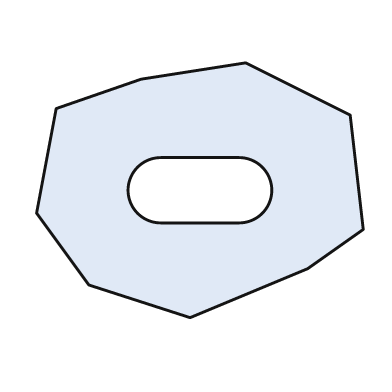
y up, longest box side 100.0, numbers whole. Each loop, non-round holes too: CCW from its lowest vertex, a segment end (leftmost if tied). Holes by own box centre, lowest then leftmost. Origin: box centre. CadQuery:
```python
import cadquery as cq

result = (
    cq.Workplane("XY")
    .moveTo(-3.0, -39.0)
    .lineTo(33.0, -24.0)
    .lineTo(50.0, -12.0)
    .lineTo(46.0, 23.0)
    .lineTo(14.0, 39.0)
    .lineTo(-18.0, 34.0)
    .lineTo(-44.0, 25.0)
    .lineTo(-50.0, -7.0)
    .lineTo(-34.0, -29.0)
    .close()
    .moveTo(-12.0, -10.0)
    .lineTo(12.0, -10.0)
    .threePointArc((22.0, 0.0), (12.0, 10.0))
    .lineTo(-12.0, 10.0)
    .threePointArc((-22.0, 0.0), (-12.0, -10.0))
    .close()
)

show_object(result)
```